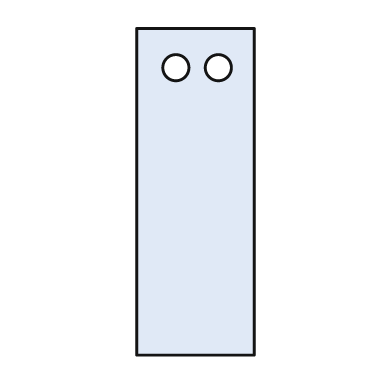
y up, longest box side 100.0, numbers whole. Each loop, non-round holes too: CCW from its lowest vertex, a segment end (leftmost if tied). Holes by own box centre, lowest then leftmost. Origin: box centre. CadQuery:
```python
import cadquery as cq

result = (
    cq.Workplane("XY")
    .moveTo(-18.0, -50.0)
    .lineTo(18.0, -50.0)
    .lineTo(18.0, 50.0)
    .lineTo(-18.0, 50.0)
    .close()
    .moveTo(-6.0, 38.0)
    .circle(4.0)
    .moveTo(7.0, 38.0)
    .circle(4.0)
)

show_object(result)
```